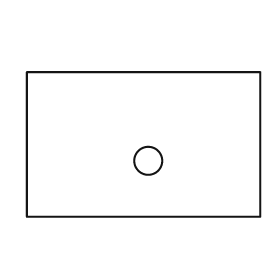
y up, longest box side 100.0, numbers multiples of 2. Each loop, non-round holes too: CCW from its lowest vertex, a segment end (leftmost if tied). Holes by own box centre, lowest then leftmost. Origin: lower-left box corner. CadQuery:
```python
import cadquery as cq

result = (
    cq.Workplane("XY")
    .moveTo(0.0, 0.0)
    .lineTo(100.0, 0.0)
    .lineTo(100.0, 62.0)
    .lineTo(0.0, 62.0)
    .close()
    .moveTo(52.0, 24.0)
    .circle(6.0)
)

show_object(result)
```